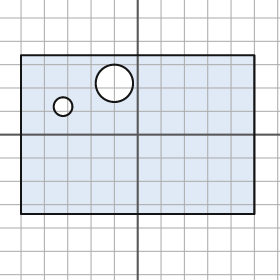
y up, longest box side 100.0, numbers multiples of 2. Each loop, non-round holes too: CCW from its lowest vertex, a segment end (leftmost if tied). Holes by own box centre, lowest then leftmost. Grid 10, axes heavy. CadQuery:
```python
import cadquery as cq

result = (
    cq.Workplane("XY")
    .moveTo(-50.0, -34.0)
    .lineTo(50.0, -34.0)
    .lineTo(50.0, 34.0)
    .lineTo(-50.0, 34.0)
    .close()
    .moveTo(-32.0, 12.0)
    .circle(4.0)
    .moveTo(-10.0, 22.0)
    .circle(8.0)
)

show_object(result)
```